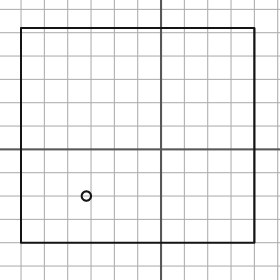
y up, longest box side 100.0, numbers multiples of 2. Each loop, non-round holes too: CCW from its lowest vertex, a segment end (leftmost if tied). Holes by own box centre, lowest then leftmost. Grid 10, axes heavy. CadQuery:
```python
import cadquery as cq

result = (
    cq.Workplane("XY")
    .moveTo(-60.0, -40.0)
    .lineTo(40.0, -40.0)
    .lineTo(40.0, 52.0)
    .lineTo(-60.0, 52.0)
    .close()
    .moveTo(-32.0, -20.0)
    .circle(2.0)
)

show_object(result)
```